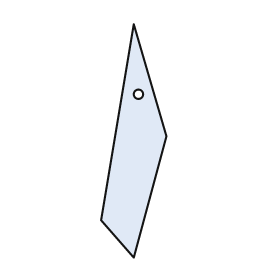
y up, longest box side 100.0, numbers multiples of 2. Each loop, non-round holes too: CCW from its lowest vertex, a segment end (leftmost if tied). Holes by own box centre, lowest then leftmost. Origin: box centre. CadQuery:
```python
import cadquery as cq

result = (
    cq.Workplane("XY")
    .moveTo(0.0, -50.0)
    .lineTo(14.0, 2.0)
    .lineTo(0.0, 50.0)
    .lineTo(-14.0, -34.0)
    .close()
    .moveTo(2.0, 20.0)
    .circle(2.0)
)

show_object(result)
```